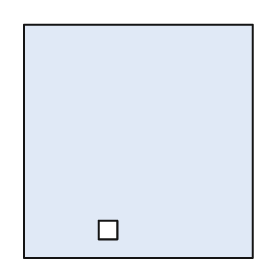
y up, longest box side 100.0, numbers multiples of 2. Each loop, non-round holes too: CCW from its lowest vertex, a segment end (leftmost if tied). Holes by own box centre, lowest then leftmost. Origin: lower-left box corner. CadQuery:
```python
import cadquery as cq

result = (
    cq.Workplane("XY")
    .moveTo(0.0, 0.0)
    .lineTo(98.0, 0.0)
    .lineTo(98.0, 100.0)
    .lineTo(0.0, 100.0)
    .close()
    .moveTo(32.0, 8.0)
    .lineTo(40.0, 8.0)
    .lineTo(40.0, 16.0)
    .lineTo(32.0, 16.0)
    .close()
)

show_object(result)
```